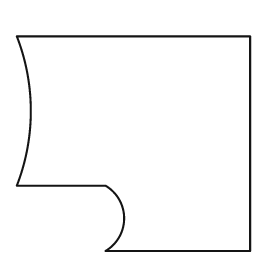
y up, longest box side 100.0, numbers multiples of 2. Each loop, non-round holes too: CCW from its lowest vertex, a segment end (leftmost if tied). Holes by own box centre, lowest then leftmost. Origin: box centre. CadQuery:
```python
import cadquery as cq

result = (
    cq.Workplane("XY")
    .moveTo(-12.0, -46.0)
    .lineTo(50.0, -46.0)
    .lineTo(50.0, 46.0)
    .lineTo(-50.0, 46.0)
    .threePointArc((-44.0, 14.0), (-50.0, -18.0))
    .lineTo(-12.0, -18.0)
    .threePointArc((-4.0, -32.0), (-12.0, -46.0))
    .close()
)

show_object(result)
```